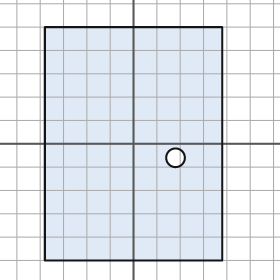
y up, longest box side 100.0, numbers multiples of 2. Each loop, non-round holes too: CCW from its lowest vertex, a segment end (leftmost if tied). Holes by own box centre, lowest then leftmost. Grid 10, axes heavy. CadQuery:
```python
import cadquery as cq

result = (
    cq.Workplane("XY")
    .moveTo(-38.0, -50.0)
    .lineTo(38.0, -50.0)
    .lineTo(38.0, 50.0)
    .lineTo(-38.0, 50.0)
    .close()
    .moveTo(18.0, -6.0)
    .circle(4.0)
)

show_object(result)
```